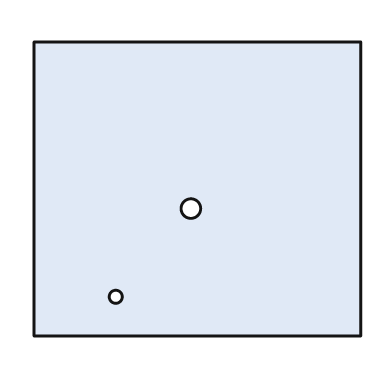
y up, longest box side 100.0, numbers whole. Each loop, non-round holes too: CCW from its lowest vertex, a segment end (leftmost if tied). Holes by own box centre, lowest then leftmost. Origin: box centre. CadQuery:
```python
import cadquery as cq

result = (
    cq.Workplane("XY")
    .moveTo(-50.0, -45.0)
    .lineTo(50.0, -45.0)
    .lineTo(50.0, 45.0)
    .lineTo(-50.0, 45.0)
    .close()
    .moveTo(-25.0, -33.0)
    .circle(2.0)
    .moveTo(-2.0, -6.0)
    .circle(3.0)
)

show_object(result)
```